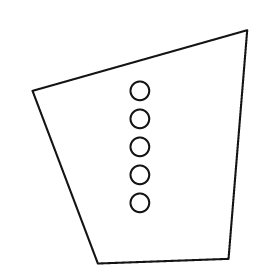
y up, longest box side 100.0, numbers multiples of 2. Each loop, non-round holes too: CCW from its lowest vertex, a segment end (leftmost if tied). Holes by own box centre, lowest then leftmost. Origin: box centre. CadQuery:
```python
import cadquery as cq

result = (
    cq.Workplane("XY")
    .moveTo(-18.0, -50.0)
    .lineTo(38.0, -48.0)
    .lineTo(46.0, 50.0)
    .lineTo(-46.0, 24.0)
    .close()
    .moveTo(0.0, -24.0)
    .circle(4.0)
    .moveTo(0.0, -12.0)
    .circle(4.0)
    .moveTo(0.0, 0.0)
    .circle(4.0)
    .moveTo(0.0, 12.0)
    .circle(4.0)
    .moveTo(0.0, 24.0)
    .circle(4.0)
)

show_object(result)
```